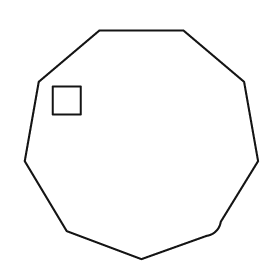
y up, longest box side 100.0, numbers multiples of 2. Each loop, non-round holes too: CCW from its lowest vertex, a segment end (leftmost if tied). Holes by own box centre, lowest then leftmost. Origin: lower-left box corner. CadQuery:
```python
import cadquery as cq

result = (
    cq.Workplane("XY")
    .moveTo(50.0, 0.0)
    .lineTo(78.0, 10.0)
    .threePointArc((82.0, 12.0), (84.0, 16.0))
    .lineTo(100.0, 42.0)
    .lineTo(94.0, 76.0)
    .lineTo(68.0, 98.0)
    .lineTo(32.0, 98.0)
    .lineTo(6.0, 76.0)
    .lineTo(0.0, 42.0)
    .lineTo(18.0, 12.0)
    .close()
    .moveTo(12.0, 62.0)
    .lineTo(24.0, 62.0)
    .lineTo(24.0, 74.0)
    .lineTo(12.0, 74.0)
    .close()
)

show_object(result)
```